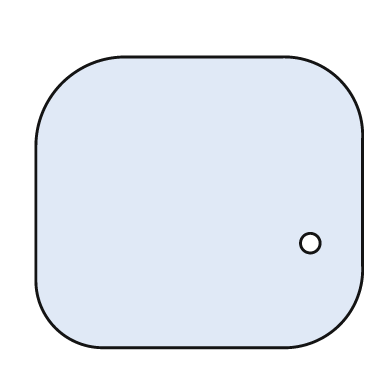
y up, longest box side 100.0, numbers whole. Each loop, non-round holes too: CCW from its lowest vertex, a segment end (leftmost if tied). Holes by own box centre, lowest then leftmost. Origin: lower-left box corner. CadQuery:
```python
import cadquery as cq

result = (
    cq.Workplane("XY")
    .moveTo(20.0, 0.0)
    .lineTo(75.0, 0.0)
    .threePointArc((93.0, 7.0), (100.0, 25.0))
    .lineTo(100.0, 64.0)
    .threePointArc((93.0, 82.0), (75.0, 89.0))
    .lineTo(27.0, 89.0)
    .threePointArc((8.0, 81.0), (0.0, 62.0))
    .lineTo(0.0, 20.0)
    .threePointArc((6.0, 6.0), (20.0, 0.0))
    .close()
    .moveTo(84.0, 32.0)
    .circle(3.0)
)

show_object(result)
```